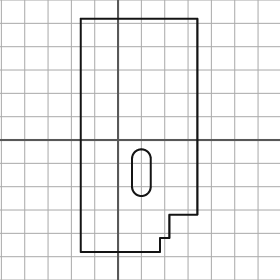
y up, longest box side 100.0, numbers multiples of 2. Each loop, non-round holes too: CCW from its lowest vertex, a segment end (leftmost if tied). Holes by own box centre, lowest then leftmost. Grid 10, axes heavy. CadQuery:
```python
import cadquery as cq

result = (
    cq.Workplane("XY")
    .moveTo(-16.0, -48.0)
    .lineTo(18.0, -48.0)
    .lineTo(18.0, -42.0)
    .lineTo(22.0, -42.0)
    .lineTo(22.0, -32.0)
    .lineTo(34.0, -32.0)
    .lineTo(34.0, 52.0)
    .lineTo(-16.0, 52.0)
    .close()
    .moveTo(6.0, -20.0)
    .threePointArc((10.0, -24.0), (14.0, -20.0))
    .lineTo(14.0, -8.0)
    .threePointArc((10.0, -4.0), (6.0, -8.0))
    .close()
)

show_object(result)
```